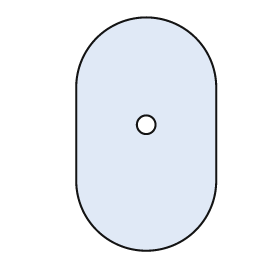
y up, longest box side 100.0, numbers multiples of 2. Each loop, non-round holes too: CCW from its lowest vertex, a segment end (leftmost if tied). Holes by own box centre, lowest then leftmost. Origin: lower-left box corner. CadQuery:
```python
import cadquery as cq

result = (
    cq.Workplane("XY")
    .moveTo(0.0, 30.0)
    .threePointArc((30.0, 0.0), (60.0, 30.0))
    .lineTo(60.0, 70.0)
    .threePointArc((30.0, 100.0), (0.0, 70.0))
    .close()
    .moveTo(30.0, 54.0)
    .circle(4.0)
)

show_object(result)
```